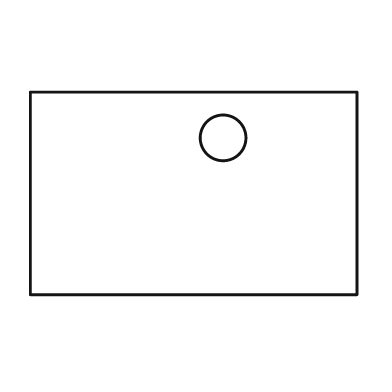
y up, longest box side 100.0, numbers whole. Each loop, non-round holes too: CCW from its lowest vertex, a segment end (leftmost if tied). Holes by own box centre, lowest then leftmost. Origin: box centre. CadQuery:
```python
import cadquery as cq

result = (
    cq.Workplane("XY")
    .moveTo(-50.0, -31.0)
    .lineTo(50.0, -31.0)
    .lineTo(50.0, 31.0)
    .lineTo(-50.0, 31.0)
    .close()
    .moveTo(9.0, 17.0)
    .circle(7.0)
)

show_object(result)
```